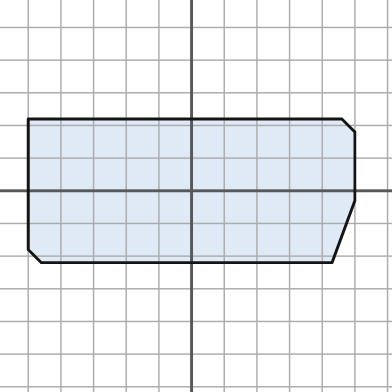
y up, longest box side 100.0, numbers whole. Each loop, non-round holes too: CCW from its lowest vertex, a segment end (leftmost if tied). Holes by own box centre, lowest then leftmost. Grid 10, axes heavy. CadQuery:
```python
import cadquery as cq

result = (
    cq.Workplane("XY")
    .moveTo(-46.0, -22.0)
    .lineTo(43.0, -22.0)
    .lineTo(50.0, -3.0)
    .lineTo(50.0, 18.0)
    .lineTo(46.0, 22.0)
    .lineTo(-50.0, 22.0)
    .lineTo(-50.0, -18.0)
    .close()
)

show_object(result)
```